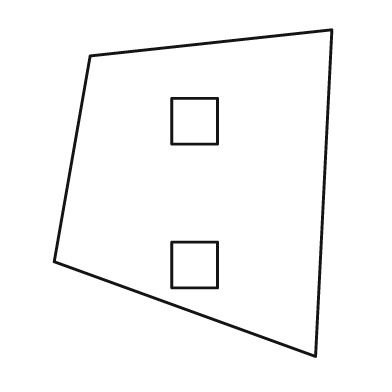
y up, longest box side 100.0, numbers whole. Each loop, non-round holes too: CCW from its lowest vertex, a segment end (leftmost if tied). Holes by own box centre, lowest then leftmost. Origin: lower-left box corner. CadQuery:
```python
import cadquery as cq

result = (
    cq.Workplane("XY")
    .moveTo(80.0, 0.0)
    .lineTo(85.0, 100.0)
    .lineTo(11.0, 92.0)
    .lineTo(0.0, 29.0)
    .close()
    .moveTo(36.0, 21.0)
    .lineTo(50.0, 21.0)
    .lineTo(50.0, 35.0)
    .lineTo(36.0, 35.0)
    .close()
    .moveTo(36.0, 65.0)
    .lineTo(50.0, 65.0)
    .lineTo(50.0, 79.0)
    .lineTo(36.0, 79.0)
    .close()
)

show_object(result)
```